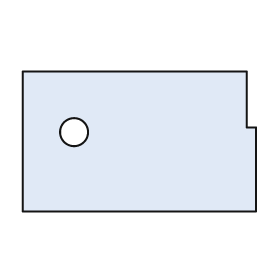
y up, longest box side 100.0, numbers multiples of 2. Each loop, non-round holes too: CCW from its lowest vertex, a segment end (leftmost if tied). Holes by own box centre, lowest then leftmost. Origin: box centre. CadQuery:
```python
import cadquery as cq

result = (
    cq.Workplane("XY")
    .moveTo(-50.0, -30.0)
    .lineTo(50.0, -30.0)
    .lineTo(50.0, 6.0)
    .lineTo(46.0, 6.0)
    .lineTo(46.0, 30.0)
    .lineTo(-50.0, 30.0)
    .close()
    .moveTo(-28.0, 4.0)
    .circle(6.0)
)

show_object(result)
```